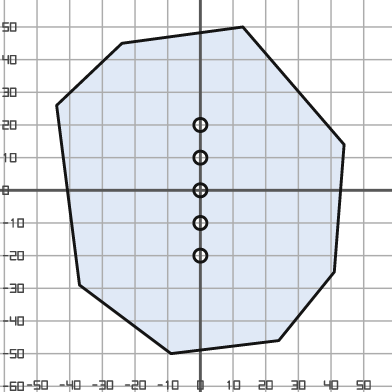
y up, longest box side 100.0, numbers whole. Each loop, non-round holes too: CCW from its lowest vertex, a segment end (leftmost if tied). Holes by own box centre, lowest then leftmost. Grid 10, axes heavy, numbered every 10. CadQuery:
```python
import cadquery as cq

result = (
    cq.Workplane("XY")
    .moveTo(-9.0, -50.0)
    .lineTo(24.0, -46.0)
    .lineTo(41.0, -25.0)
    .lineTo(44.0, 14.0)
    .lineTo(13.0, 50.0)
    .lineTo(-24.0, 45.0)
    .lineTo(-44.0, 26.0)
    .lineTo(-37.0, -29.0)
    .close()
    .moveTo(0.0, -20.0)
    .circle(2.0)
    .moveTo(0.0, -10.0)
    .circle(2.0)
    .moveTo(0.0, 0.0)
    .circle(2.0)
    .moveTo(0.0, 10.0)
    .circle(2.0)
    .moveTo(0.0, 20.0)
    .circle(2.0)
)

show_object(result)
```